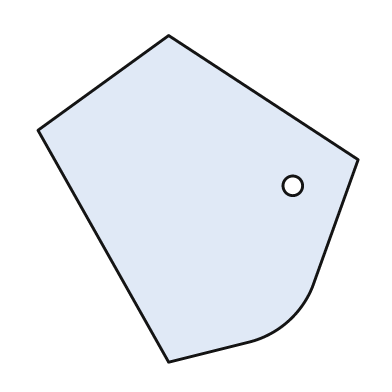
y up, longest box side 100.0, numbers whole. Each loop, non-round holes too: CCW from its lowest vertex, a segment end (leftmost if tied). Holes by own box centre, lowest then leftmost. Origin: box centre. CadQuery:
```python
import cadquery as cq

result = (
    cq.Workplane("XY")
    .moveTo(-9.0, -50.0)
    .lineTo(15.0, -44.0)
    .threePointArc((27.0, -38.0), (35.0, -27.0))
    .lineTo(49.0, 12.0)
    .lineTo(-9.0, 50.0)
    .lineTo(-49.0, 21.0)
    .close()
    .moveTo(29.0, 4.0)
    .circle(3.0)
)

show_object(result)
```